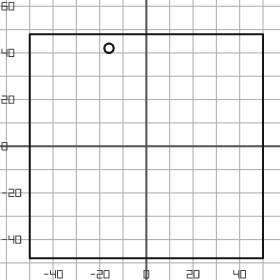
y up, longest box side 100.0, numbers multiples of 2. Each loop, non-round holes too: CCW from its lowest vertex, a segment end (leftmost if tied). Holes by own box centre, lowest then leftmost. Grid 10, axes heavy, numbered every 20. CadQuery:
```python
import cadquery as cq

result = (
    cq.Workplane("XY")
    .moveTo(-50.0, -48.0)
    .lineTo(50.0, -48.0)
    .lineTo(50.0, 48.0)
    .lineTo(-50.0, 48.0)
    .close()
    .moveTo(-16.0, 42.0)
    .circle(2.0)
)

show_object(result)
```